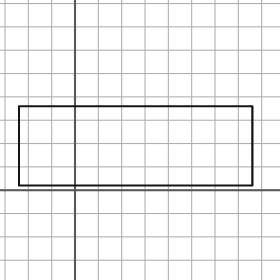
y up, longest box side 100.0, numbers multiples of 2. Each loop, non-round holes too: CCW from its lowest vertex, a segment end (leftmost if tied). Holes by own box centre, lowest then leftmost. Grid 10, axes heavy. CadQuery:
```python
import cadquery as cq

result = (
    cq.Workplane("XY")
    .moveTo(-24.0, 2.0)
    .lineTo(76.0, 2.0)
    .lineTo(76.0, 36.0)
    .lineTo(-24.0, 36.0)
    .close()
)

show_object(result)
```